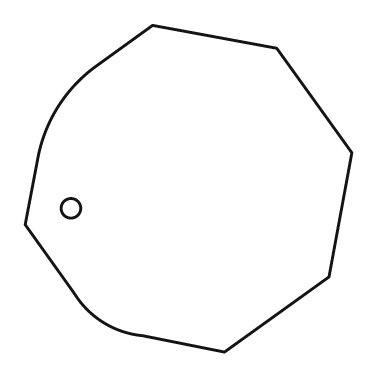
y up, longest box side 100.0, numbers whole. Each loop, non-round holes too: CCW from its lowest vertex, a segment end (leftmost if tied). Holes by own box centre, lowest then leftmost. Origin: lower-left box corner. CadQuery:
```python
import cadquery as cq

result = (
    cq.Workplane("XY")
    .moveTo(61.0, 0.0)
    .lineTo(93.0, 23.0)
    .lineTo(100.0, 61.0)
    .lineTo(77.0, 93.0)
    .lineTo(39.0, 100.0)
    .lineTo(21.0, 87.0)
    .threePointArc((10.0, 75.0), (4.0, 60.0))
    .lineTo(0.0, 39.0)
    .lineTo(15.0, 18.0)
    .threePointArc((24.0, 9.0), (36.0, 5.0))
    .close()
    .moveTo(14.0, 44.0)
    .circle(3.0)
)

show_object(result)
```